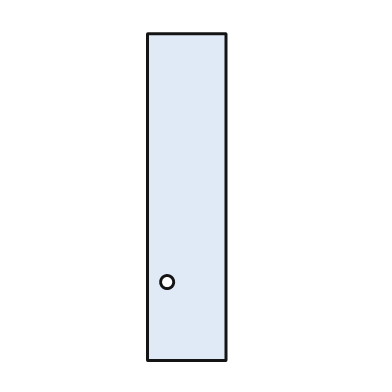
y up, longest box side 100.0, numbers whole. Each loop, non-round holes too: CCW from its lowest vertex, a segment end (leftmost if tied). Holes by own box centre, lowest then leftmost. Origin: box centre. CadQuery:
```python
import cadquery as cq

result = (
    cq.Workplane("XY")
    .moveTo(-12.0, -50.0)
    .lineTo(12.0, -50.0)
    .lineTo(12.0, 50.0)
    .lineTo(-12.0, 50.0)
    .close()
    .moveTo(-6.0, -26.0)
    .circle(2.0)
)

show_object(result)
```